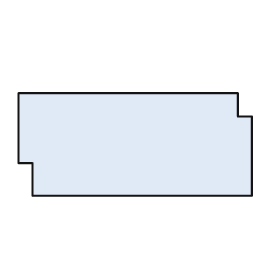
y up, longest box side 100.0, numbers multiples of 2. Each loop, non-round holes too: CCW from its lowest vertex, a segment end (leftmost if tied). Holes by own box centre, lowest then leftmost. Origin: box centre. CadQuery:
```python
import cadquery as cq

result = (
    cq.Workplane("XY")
    .moveTo(-44.0, -22.0)
    .lineTo(50.0, -22.0)
    .lineTo(50.0, 12.0)
    .lineTo(44.0, 12.0)
    .lineTo(44.0, 22.0)
    .lineTo(-50.0, 22.0)
    .lineTo(-50.0, -8.0)
    .lineTo(-44.0, -8.0)
    .close()
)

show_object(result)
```